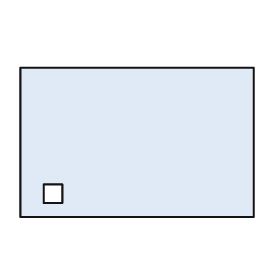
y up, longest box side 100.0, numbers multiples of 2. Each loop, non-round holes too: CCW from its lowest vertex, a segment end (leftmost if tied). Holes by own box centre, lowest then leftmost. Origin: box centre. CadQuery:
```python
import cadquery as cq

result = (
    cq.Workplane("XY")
    .moveTo(-50.0, -32.0)
    .lineTo(50.0, -32.0)
    .lineTo(50.0, 32.0)
    .lineTo(-50.0, 32.0)
    .close()
    .moveTo(-40.0, -26.0)
    .lineTo(-32.0, -26.0)
    .lineTo(-32.0, -18.0)
    .lineTo(-40.0, -18.0)
    .close()
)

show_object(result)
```